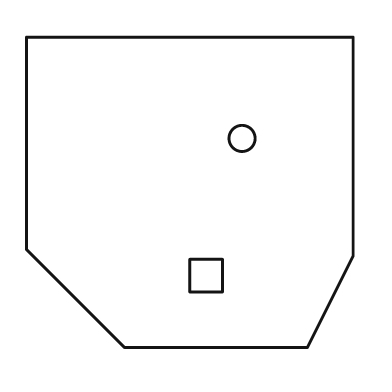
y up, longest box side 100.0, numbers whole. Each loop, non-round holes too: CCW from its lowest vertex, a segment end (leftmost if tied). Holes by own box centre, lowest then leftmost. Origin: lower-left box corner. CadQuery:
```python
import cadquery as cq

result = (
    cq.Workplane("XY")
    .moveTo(30.0, 0.0)
    .lineTo(86.0, 0.0)
    .lineTo(100.0, 28.0)
    .lineTo(100.0, 95.0)
    .lineTo(0.0, 95.0)
    .lineTo(0.0, 30.0)
    .close()
    .moveTo(50.0, 17.0)
    .lineTo(60.0, 17.0)
    .lineTo(60.0, 27.0)
    .lineTo(50.0, 27.0)
    .close()
    .moveTo(66.0, 64.0)
    .circle(4.0)
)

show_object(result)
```